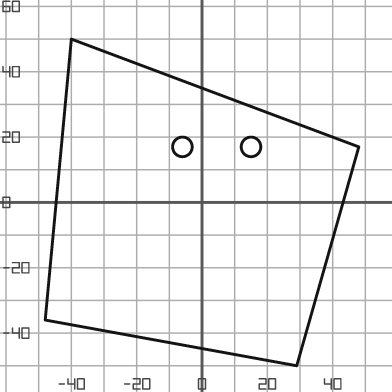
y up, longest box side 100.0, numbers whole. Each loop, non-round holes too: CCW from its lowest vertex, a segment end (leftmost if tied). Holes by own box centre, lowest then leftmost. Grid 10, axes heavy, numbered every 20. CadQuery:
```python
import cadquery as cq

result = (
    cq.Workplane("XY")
    .moveTo(29.0, -50.0)
    .lineTo(48.0, 17.0)
    .lineTo(-40.0, 50.0)
    .lineTo(-48.0, -36.0)
    .close()
    .moveTo(-6.0, 17.0)
    .circle(3.0)
    .moveTo(15.0, 17.0)
    .circle(3.0)
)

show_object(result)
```